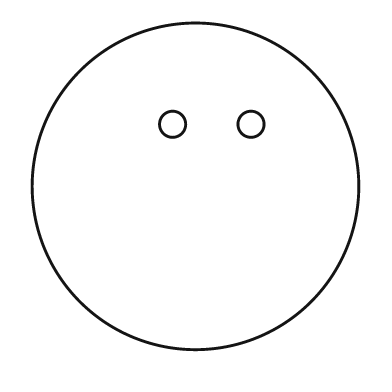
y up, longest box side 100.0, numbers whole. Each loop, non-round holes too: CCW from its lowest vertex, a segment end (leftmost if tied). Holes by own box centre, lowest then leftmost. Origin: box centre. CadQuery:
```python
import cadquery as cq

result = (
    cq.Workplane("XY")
    .moveTo(0.0, 0.0)
    .circle(50.0)
    .moveTo(-7.0, 19.0)
    .circle(4.0)
    .moveTo(17.0, 19.0)
    .circle(4.0)
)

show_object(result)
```